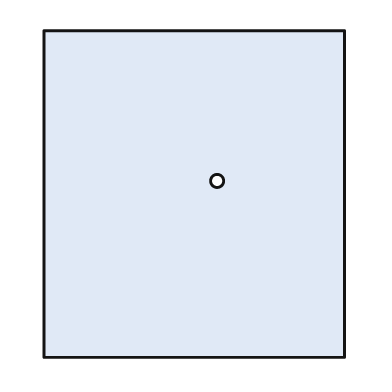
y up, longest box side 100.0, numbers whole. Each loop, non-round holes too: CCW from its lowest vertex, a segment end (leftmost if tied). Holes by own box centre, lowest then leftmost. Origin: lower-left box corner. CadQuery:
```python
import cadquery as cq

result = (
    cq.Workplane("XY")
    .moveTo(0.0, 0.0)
    .lineTo(92.0, 0.0)
    .lineTo(92.0, 100.0)
    .lineTo(0.0, 100.0)
    .close()
    .moveTo(53.0, 54.0)
    .circle(2.0)
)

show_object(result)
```